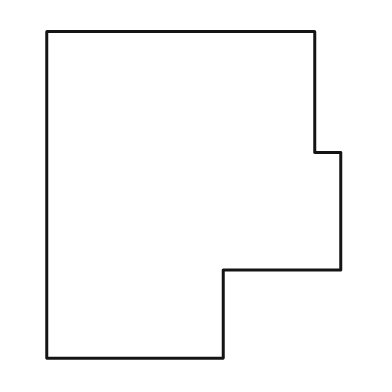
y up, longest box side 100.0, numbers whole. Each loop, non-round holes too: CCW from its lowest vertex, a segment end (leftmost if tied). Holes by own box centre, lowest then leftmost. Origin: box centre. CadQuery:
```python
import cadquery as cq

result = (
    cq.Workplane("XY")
    .moveTo(-45.0, -50.0)
    .lineTo(9.0, -50.0)
    .lineTo(9.0, -23.0)
    .lineTo(45.0, -23.0)
    .lineTo(45.0, 13.0)
    .lineTo(37.0, 13.0)
    .lineTo(37.0, 50.0)
    .lineTo(-45.0, 50.0)
    .close()
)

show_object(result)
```